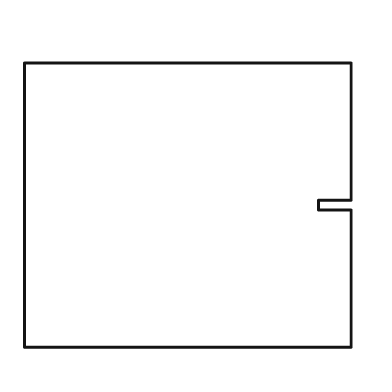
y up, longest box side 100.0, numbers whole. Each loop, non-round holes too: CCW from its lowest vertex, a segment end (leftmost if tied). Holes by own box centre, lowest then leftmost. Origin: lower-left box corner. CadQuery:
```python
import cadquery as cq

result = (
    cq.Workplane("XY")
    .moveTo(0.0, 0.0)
    .lineTo(100.0, 0.0)
    .lineTo(100.0, 42.0)
    .lineTo(90.0, 42.0)
    .lineTo(90.0, 45.0)
    .lineTo(100.0, 45.0)
    .lineTo(100.0, 87.0)
    .lineTo(0.0, 87.0)
    .close()
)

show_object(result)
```